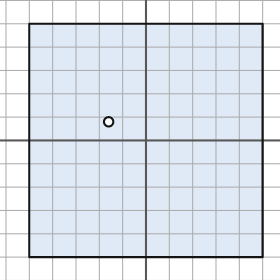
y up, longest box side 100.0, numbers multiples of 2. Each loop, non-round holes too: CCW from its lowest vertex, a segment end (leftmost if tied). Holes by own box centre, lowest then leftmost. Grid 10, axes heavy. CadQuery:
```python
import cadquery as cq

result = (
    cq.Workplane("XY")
    .moveTo(-50.0, -50.0)
    .lineTo(50.0, -50.0)
    .lineTo(50.0, 50.0)
    .lineTo(-50.0, 50.0)
    .close()
    .moveTo(-16.0, 8.0)
    .circle(2.0)
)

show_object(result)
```